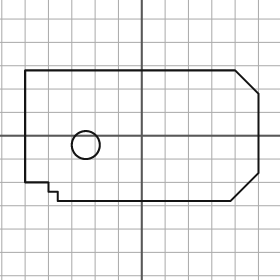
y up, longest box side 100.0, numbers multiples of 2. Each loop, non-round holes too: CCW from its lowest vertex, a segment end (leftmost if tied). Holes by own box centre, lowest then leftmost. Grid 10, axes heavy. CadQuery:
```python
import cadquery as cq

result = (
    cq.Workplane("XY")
    .moveTo(-36.0, -28.0)
    .lineTo(38.0, -28.0)
    .lineTo(50.0, -16.0)
    .lineTo(50.0, 18.0)
    .lineTo(40.0, 28.0)
    .lineTo(-50.0, 28.0)
    .lineTo(-50.0, -20.0)
    .lineTo(-40.0, -20.0)
    .lineTo(-40.0, -24.0)
    .lineTo(-36.0, -24.0)
    .close()
    .moveTo(-24.0, -4.0)
    .circle(6.0)
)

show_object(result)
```